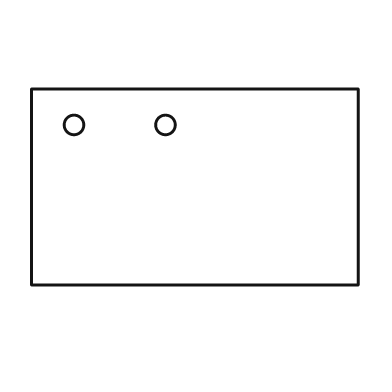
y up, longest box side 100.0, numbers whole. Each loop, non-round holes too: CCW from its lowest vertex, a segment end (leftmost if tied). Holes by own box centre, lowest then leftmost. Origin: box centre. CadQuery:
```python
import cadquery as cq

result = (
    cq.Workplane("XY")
    .moveTo(-50.0, -30.0)
    .lineTo(50.0, -30.0)
    .lineTo(50.0, 30.0)
    .lineTo(-50.0, 30.0)
    .close()
    .moveTo(-37.0, 19.0)
    .circle(3.0)
    .moveTo(-9.0, 19.0)
    .circle(3.0)
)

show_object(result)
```